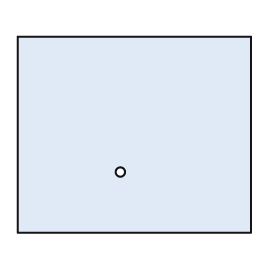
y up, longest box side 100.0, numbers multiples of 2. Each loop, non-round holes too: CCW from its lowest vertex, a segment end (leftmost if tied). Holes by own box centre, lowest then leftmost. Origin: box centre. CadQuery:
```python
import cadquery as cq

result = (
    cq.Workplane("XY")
    .moveTo(-50.0, -42.0)
    .lineTo(50.0, -42.0)
    .lineTo(50.0, 42.0)
    .lineTo(-50.0, 42.0)
    .close()
    .moveTo(-6.0, -16.0)
    .circle(2.0)
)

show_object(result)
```